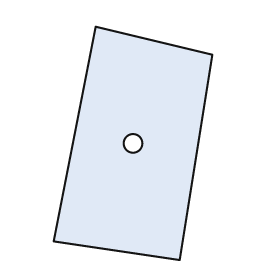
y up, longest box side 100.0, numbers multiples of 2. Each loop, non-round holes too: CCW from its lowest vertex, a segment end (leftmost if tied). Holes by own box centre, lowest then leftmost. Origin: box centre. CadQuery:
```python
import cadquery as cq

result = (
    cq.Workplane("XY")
    .moveTo(20.0, -50.0)
    .lineTo(34.0, 38.0)
    .lineTo(-16.0, 50.0)
    .lineTo(-34.0, -42.0)
    .close()
    .moveTo(0.0, 0.0)
    .circle(4.0)
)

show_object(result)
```